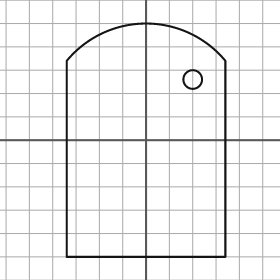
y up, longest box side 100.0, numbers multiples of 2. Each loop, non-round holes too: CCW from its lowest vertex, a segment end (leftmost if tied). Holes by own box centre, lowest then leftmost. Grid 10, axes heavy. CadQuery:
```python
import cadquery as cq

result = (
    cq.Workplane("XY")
    .moveTo(-34.0, -50.0)
    .lineTo(34.0, -50.0)
    .lineTo(34.0, 34.0)
    .threePointArc((0.0, 50.0), (-34.0, 34.0))
    .close()
    .moveTo(20.0, 26.0)
    .circle(4.0)
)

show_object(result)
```